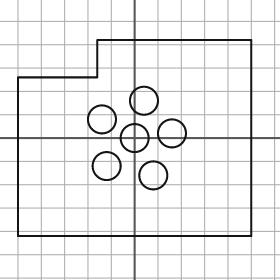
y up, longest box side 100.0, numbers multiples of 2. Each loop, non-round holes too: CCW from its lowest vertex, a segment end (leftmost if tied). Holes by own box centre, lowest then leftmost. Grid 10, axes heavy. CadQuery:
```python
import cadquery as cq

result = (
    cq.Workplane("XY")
    .moveTo(-50.0, -42.0)
    .lineTo(50.0, -42.0)
    .lineTo(50.0, 42.0)
    .lineTo(-16.0, 42.0)
    .lineTo(-16.0, 26.0)
    .lineTo(-50.0, 26.0)
    .close()
    .moveTo(8.0, -16.0)
    .circle(6.0)
    .moveTo(-12.0, -12.0)
    .circle(6.0)
    .moveTo(0.0, 0.0)
    .circle(6.0)
    .moveTo(16.0, 2.0)
    .circle(6.0)
    .moveTo(-14.0, 8.0)
    .circle(6.0)
    .moveTo(4.0, 16.0)
    .circle(6.0)
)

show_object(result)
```